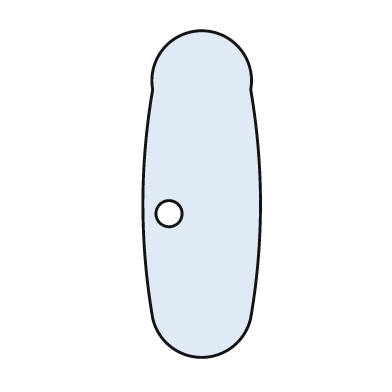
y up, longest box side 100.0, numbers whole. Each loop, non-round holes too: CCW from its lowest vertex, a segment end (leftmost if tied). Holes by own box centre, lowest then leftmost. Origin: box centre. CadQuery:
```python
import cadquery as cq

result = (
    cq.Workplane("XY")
    .moveTo(-15.0, -38.0)
    .threePointArc((0.0, -50.0), (15.0, -38.0))
    .threePointArc((18.0, -3.0), (15.0, 32.0))
    .threePointArc((0.0, 50.0), (-15.0, 32.0))
    .threePointArc((-18.0, -3.0), (-15.0, -38.0))
    .close()
    .moveTo(-10.0, -6.0)
    .circle(4.0)
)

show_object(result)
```